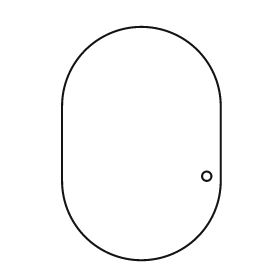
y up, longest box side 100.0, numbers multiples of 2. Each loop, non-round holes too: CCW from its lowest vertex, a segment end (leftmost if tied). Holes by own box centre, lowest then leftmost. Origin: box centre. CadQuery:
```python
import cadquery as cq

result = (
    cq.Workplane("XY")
    .moveTo(-34.0, -16.0)
    .threePointArc((0.0, -50.0), (34.0, -16.0))
    .lineTo(34.0, 16.0)
    .threePointArc((0.0, 50.0), (-34.0, 16.0))
    .close()
    .moveTo(28.0, -14.0)
    .circle(2.0)
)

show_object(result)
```